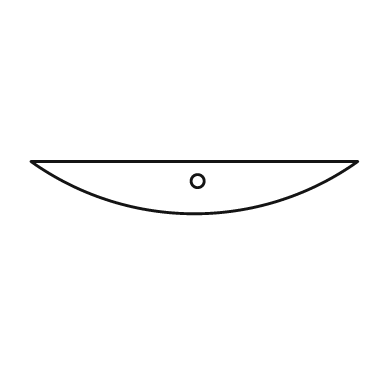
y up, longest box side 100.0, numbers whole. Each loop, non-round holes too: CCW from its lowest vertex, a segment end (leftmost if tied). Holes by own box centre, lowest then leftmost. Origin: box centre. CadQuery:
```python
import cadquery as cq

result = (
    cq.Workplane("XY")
    .moveTo(-50.0, 8.0)
    .threePointArc((0.0, -8.0), (50.0, 8.0))
    .close()
    .moveTo(1.0, 2.0)
    .circle(2.0)
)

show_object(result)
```